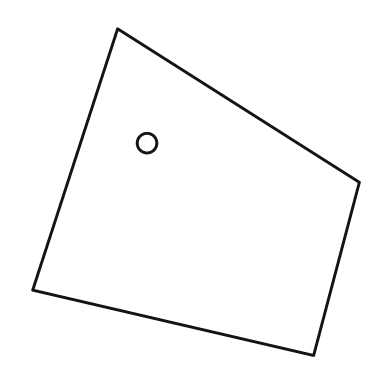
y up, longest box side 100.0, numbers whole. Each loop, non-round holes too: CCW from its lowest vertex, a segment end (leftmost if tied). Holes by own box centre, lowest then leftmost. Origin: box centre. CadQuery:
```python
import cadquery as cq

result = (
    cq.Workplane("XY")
    .moveTo(36.0, -50.0)
    .lineTo(50.0, 3.0)
    .lineTo(-24.0, 50.0)
    .lineTo(-50.0, -30.0)
    .close()
    .moveTo(-15.0, 15.0)
    .circle(3.0)
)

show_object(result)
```